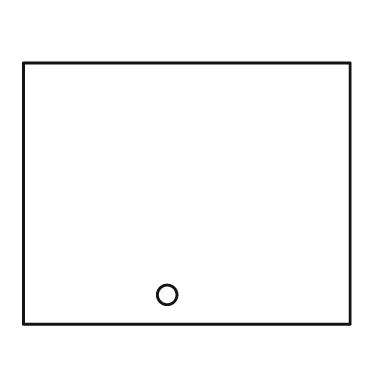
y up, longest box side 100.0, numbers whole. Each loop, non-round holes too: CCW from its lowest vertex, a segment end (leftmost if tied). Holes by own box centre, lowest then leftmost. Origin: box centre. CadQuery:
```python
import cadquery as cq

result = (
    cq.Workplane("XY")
    .moveTo(-50.0, -40.0)
    .lineTo(50.0, -40.0)
    .lineTo(50.0, 40.0)
    .lineTo(-50.0, 40.0)
    .close()
    .moveTo(-6.0, -31.0)
    .circle(3.0)
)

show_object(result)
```